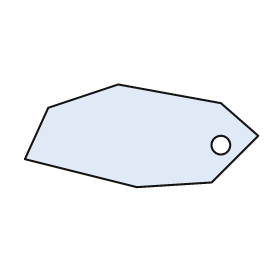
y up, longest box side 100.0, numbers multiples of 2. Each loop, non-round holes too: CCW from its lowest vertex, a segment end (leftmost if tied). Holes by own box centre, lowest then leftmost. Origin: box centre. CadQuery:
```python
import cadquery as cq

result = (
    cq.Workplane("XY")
    .moveTo(-2.0, -22.0)
    .lineTo(30.0, -20.0)
    .lineTo(50.0, 0.0)
    .lineTo(34.0, 14.0)
    .lineTo(-10.0, 22.0)
    .lineTo(-40.0, 12.0)
    .lineTo(-50.0, -10.0)
    .close()
    .moveTo(34.0, -4.0)
    .circle(4.0)
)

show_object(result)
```